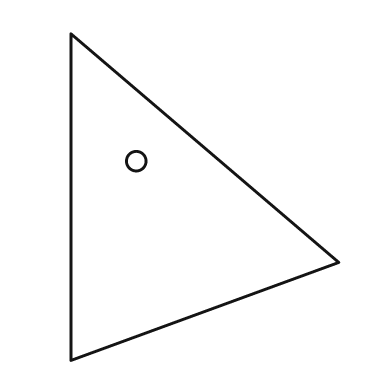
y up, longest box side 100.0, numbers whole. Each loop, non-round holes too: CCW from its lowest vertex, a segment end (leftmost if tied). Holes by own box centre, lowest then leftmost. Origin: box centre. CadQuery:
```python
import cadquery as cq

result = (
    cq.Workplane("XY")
    .moveTo(-41.0, -50.0)
    .lineTo(41.0, -20.0)
    .lineTo(-41.0, 50.0)
    .close()
    .moveTo(-21.0, 11.0)
    .circle(3.0)
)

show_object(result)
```